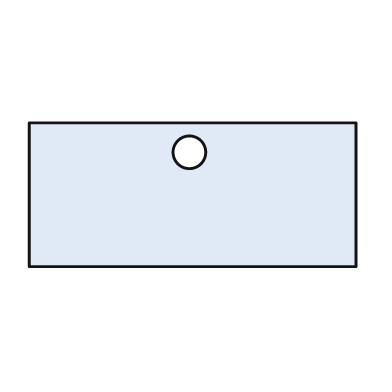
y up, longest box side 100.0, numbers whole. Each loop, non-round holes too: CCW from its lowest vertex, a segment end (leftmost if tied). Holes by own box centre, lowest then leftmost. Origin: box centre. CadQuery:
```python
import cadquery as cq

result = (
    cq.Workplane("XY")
    .moveTo(-50.0, -22.0)
    .lineTo(50.0, -22.0)
    .lineTo(50.0, 22.0)
    .lineTo(-50.0, 22.0)
    .close()
    .moveTo(-1.0, 13.0)
    .circle(5.0)
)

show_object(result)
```